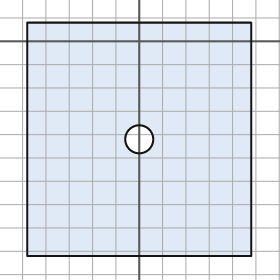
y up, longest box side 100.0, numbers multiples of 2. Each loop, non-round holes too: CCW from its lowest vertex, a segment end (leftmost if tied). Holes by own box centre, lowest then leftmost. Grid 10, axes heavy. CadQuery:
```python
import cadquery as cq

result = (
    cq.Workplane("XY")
    .moveTo(-48.0, -92.0)
    .lineTo(48.0, -92.0)
    .lineTo(48.0, 8.0)
    .lineTo(-48.0, 8.0)
    .close()
    .moveTo(0.0, -42.0)
    .circle(6.0)
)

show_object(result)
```